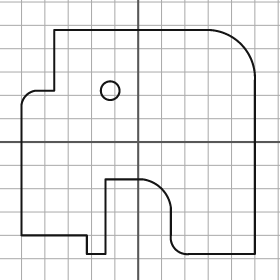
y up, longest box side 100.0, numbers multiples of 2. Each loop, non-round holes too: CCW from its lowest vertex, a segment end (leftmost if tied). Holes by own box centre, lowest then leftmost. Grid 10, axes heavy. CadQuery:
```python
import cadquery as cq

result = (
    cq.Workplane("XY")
    .moveTo(-22.0, -48.0)
    .lineTo(-14.0, -48.0)
    .lineTo(-14.0, -16.0)
    .lineTo(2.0, -16.0)
    .threePointArc((10.0, -20.0), (14.0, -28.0))
    .lineTo(14.0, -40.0)
    .threePointArc((16.0, -46.0), (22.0, -48.0))
    .lineTo(50.0, -48.0)
    .lineTo(50.0, 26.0)
    .threePointArc((44.0, 42.0), (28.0, 48.0))
    .lineTo(-36.0, 48.0)
    .lineTo(-36.0, 22.0)
    .lineTo(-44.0, 22.0)
    .threePointArc((-48.0, 20.0), (-50.0, 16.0))
    .lineTo(-50.0, -40.0)
    .lineTo(-22.0, -40.0)
    .close()
    .moveTo(-12.0, 22.0)
    .circle(4.0)
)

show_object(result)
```